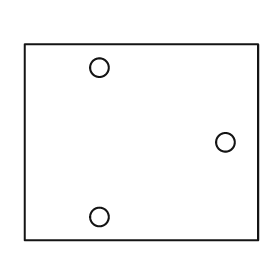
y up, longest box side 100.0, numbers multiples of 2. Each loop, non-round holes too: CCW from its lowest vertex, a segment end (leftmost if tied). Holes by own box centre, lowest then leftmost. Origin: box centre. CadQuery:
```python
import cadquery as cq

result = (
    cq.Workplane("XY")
    .moveTo(-50.0, -42.0)
    .lineTo(50.0, -42.0)
    .lineTo(50.0, 42.0)
    .lineTo(-50.0, 42.0)
    .close()
    .moveTo(-18.0, -32.0)
    .circle(4.0)
    .moveTo(36.0, 0.0)
    .circle(4.0)
    .moveTo(-18.0, 32.0)
    .circle(4.0)
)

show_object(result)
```